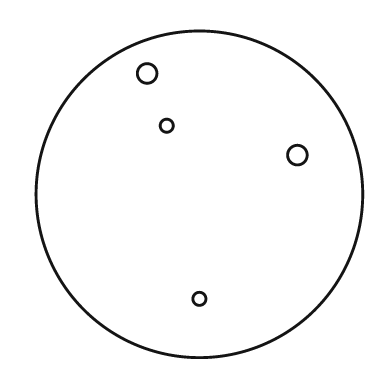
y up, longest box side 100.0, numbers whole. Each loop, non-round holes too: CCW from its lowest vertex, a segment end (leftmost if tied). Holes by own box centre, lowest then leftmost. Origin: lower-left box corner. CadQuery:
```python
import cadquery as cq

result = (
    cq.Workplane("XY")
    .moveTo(50.0, 50.0)
    .circle(50.0)
    .moveTo(50.0, 18.0)
    .circle(2.0)
    .moveTo(80.0, 62.0)
    .circle(3.0)
    .moveTo(40.0, 71.0)
    .circle(2.0)
    .moveTo(34.0, 87.0)
    .circle(3.0)
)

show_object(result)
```